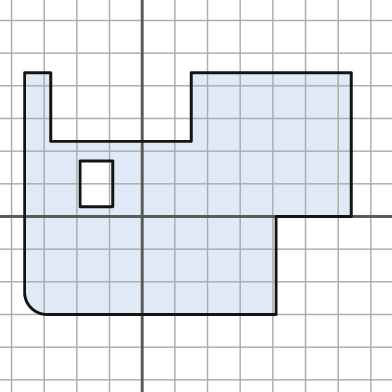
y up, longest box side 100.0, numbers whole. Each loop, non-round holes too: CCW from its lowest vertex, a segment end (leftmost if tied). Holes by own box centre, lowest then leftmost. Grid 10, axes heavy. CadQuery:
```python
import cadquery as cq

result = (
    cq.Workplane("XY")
    .moveTo(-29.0, -30.0)
    .lineTo(41.0, -30.0)
    .lineTo(41.0, 0.0)
    .lineTo(64.0, 0.0)
    .lineTo(64.0, 44.0)
    .lineTo(15.0, 44.0)
    .lineTo(15.0, 23.0)
    .lineTo(-28.0, 23.0)
    .lineTo(-28.0, 44.0)
    .lineTo(-36.0, 44.0)
    .lineTo(-36.0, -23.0)
    .threePointArc((-34.0, -28.0), (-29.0, -30.0))
    .close()
    .moveTo(-19.0, 3.0)
    .lineTo(-9.0, 3.0)
    .lineTo(-9.0, 17.0)
    .lineTo(-19.0, 17.0)
    .close()
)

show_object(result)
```